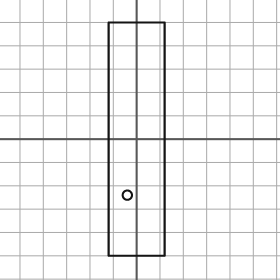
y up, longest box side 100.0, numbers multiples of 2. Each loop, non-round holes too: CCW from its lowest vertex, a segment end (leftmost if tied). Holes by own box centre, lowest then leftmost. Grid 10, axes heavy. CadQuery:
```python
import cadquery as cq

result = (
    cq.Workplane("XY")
    .moveTo(-12.0, -50.0)
    .lineTo(12.0, -50.0)
    .lineTo(12.0, 50.0)
    .lineTo(-12.0, 50.0)
    .close()
    .moveTo(-4.0, -24.0)
    .circle(2.0)
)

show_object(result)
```